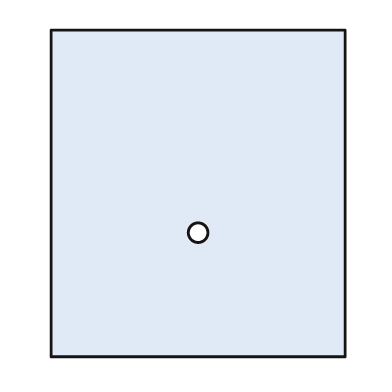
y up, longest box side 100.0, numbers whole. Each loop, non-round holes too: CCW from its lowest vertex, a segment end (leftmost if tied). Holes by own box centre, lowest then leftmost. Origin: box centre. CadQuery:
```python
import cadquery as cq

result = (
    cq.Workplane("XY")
    .moveTo(-45.0, -50.0)
    .lineTo(45.0, -50.0)
    .lineTo(45.0, 50.0)
    .lineTo(-45.0, 50.0)
    .close()
    .moveTo(0.0, -12.0)
    .circle(3.0)
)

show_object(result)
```